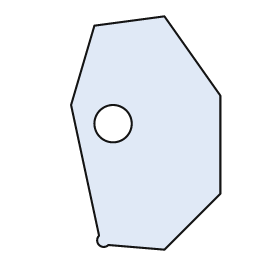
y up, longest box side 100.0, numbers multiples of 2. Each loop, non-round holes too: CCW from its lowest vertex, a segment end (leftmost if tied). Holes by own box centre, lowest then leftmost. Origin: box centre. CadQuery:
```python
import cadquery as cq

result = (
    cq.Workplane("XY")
    .moveTo(8.0, -50.0)
    .lineTo(32.0, -26.0)
    .lineTo(32.0, 16.0)
    .lineTo(8.0, 50.0)
    .lineTo(-22.0, 46.0)
    .lineTo(-32.0, 12.0)
    .lineTo(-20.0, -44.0)
    .threePointArc((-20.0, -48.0), (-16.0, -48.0))
    .close()
    .moveTo(-14.0, 4.0)
    .circle(8.0)
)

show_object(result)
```